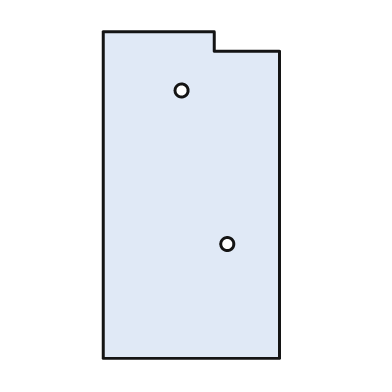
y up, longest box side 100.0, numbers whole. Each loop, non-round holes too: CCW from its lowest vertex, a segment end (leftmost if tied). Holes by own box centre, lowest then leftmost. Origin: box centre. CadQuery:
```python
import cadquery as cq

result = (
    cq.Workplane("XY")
    .moveTo(-27.0, -50.0)
    .lineTo(27.0, -50.0)
    .lineTo(27.0, 44.0)
    .lineTo(7.0, 44.0)
    .lineTo(7.0, 50.0)
    .lineTo(-27.0, 50.0)
    .close()
    .moveTo(11.0, -15.0)
    .circle(2.0)
    .moveTo(-3.0, 32.0)
    .circle(2.0)
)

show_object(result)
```